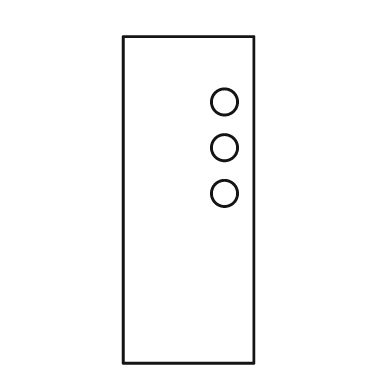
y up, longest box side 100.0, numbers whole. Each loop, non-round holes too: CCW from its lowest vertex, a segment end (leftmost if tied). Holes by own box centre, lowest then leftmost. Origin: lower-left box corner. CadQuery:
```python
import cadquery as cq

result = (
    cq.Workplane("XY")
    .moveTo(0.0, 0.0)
    .lineTo(40.0, 0.0)
    .lineTo(40.0, 100.0)
    .lineTo(0.0, 100.0)
    .close()
    .moveTo(31.0, 52.0)
    .circle(4.0)
    .moveTo(31.0, 66.0)
    .circle(4.0)
    .moveTo(31.0, 80.0)
    .circle(4.0)
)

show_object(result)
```